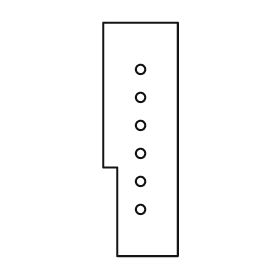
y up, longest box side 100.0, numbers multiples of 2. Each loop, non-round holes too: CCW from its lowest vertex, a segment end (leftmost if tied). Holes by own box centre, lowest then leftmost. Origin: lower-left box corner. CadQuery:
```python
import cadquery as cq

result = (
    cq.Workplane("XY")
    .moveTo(6.0, 0.0)
    .lineTo(32.0, 0.0)
    .lineTo(32.0, 100.0)
    .lineTo(0.0, 100.0)
    .lineTo(0.0, 38.0)
    .lineTo(6.0, 38.0)
    .close()
    .moveTo(16.0, 20.0)
    .circle(2.0)
    .moveTo(16.0, 32.0)
    .circle(2.0)
    .moveTo(16.0, 44.0)
    .circle(2.0)
    .moveTo(16.0, 56.0)
    .circle(2.0)
    .moveTo(16.0, 68.0)
    .circle(2.0)
    .moveTo(16.0, 80.0)
    .circle(2.0)
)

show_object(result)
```